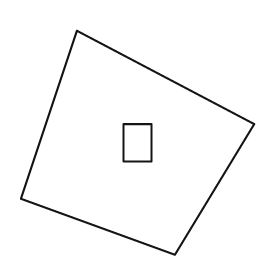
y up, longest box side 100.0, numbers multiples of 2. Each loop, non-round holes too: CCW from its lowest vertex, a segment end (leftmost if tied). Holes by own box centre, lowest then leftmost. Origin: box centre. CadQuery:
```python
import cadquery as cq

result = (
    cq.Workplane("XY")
    .moveTo(16.0, -48.0)
    .lineTo(50.0, 8.0)
    .lineTo(-26.0, 48.0)
    .lineTo(-50.0, -24.0)
    .close()
    .moveTo(-6.0, -8.0)
    .lineTo(6.0, -8.0)
    .lineTo(6.0, 8.0)
    .lineTo(-6.0, 8.0)
    .close()
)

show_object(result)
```